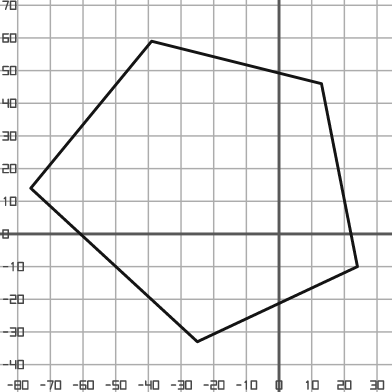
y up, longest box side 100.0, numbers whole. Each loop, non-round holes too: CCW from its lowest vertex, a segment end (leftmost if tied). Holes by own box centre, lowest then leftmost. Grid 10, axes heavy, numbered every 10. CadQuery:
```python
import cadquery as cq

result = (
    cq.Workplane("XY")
    .moveTo(-25.0, -33.0)
    .lineTo(24.0, -10.0)
    .lineTo(13.0, 46.0)
    .lineTo(-39.0, 59.0)
    .lineTo(-76.0, 14.0)
    .close()
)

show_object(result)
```